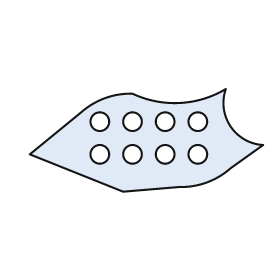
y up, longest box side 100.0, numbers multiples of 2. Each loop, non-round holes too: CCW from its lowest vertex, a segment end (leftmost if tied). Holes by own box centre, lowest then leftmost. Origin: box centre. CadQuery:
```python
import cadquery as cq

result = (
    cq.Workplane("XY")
    .moveTo(-10.0, -22.0)
    .lineTo(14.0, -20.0)
    .threePointArc((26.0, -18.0), (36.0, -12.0))
    .lineTo(50.0, -2.0)
    .threePointArc((36.0, 6.0), (34.0, 22.0))
    .threePointArc((14.0, 16.0), (-6.0, 20.0))
    .threePointArc((-18.0, 18.0), (-28.0, 12.0))
    .lineTo(-50.0, -6.0)
    .close()
    .moveTo(-20.0, -6.0)
    .circle(4.0)
    .moveTo(-6.0, -6.0)
    .circle(4.0)
    .moveTo(8.0, -6.0)
    .circle(4.0)
    .moveTo(22.0, -6.0)
    .circle(4.0)
    .moveTo(-20.0, 8.0)
    .circle(4.0)
    .moveTo(-6.0, 8.0)
    .circle(4.0)
    .moveTo(8.0, 8.0)
    .circle(4.0)
    .moveTo(22.0, 8.0)
    .circle(4.0)
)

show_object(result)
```